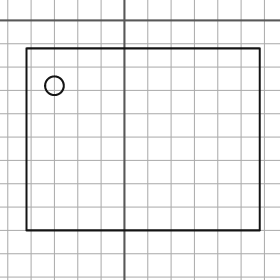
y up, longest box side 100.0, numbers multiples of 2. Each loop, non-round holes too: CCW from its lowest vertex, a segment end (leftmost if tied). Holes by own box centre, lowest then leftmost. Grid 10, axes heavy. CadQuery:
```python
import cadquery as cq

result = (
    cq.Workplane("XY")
    .moveTo(-42.0, -90.0)
    .lineTo(58.0, -90.0)
    .lineTo(58.0, -12.0)
    .lineTo(-42.0, -12.0)
    .close()
    .moveTo(-30.0, -28.0)
    .circle(4.0)
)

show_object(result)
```